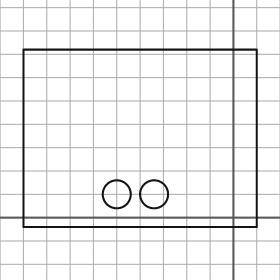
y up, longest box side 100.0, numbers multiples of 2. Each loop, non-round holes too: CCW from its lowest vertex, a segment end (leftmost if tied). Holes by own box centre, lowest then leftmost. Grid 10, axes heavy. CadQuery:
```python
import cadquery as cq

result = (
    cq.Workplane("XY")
    .moveTo(-90.0, -4.0)
    .lineTo(10.0, -4.0)
    .lineTo(10.0, 72.0)
    .lineTo(-90.0, 72.0)
    .close()
    .moveTo(-50.0, 10.0)
    .circle(6.0)
    .moveTo(-34.0, 10.0)
    .circle(6.0)
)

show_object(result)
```